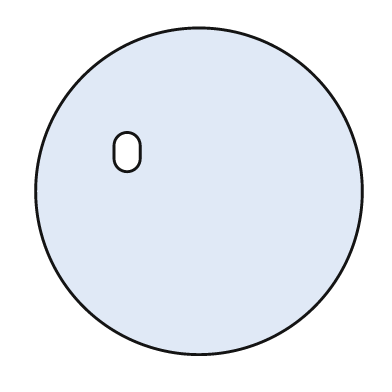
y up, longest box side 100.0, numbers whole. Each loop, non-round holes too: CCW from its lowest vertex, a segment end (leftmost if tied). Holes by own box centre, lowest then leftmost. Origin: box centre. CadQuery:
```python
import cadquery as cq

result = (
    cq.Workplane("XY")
    .moveTo(0.0, 0.0)
    .circle(50.0)
    .moveTo(-26.0, 10.0)
    .threePointArc((-22.0, 6.0), (-18.0, 10.0))
    .lineTo(-18.0, 14.0)
    .threePointArc((-22.0, 18.0), (-26.0, 14.0))
    .close()
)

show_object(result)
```